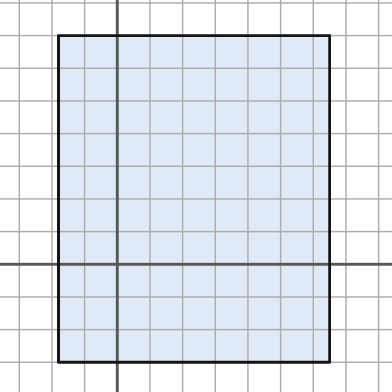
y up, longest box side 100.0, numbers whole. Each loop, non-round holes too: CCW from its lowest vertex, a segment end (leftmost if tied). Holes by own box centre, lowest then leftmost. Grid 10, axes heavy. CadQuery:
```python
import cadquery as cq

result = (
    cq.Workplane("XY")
    .moveTo(-18.0, -30.0)
    .lineTo(65.0, -30.0)
    .lineTo(65.0, 70.0)
    .lineTo(-18.0, 70.0)
    .close()
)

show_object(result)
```